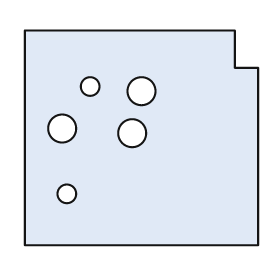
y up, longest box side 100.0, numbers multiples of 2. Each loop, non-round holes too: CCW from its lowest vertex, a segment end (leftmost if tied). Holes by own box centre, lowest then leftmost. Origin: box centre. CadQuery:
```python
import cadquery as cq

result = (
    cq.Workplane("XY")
    .moveTo(-50.0, -46.0)
    .lineTo(50.0, -46.0)
    .lineTo(50.0, 30.0)
    .lineTo(40.0, 30.0)
    .lineTo(40.0, 46.0)
    .lineTo(-50.0, 46.0)
    .close()
    .moveTo(-32.0, -24.0)
    .circle(4.0)
    .moveTo(-4.0, 2.0)
    .circle(6.0)
    .moveTo(-34.0, 4.0)
    .circle(6.0)
    .moveTo(0.0, 20.0)
    .circle(6.0)
    .moveTo(-22.0, 22.0)
    .circle(4.0)
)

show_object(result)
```